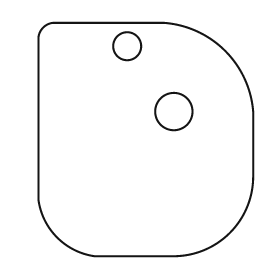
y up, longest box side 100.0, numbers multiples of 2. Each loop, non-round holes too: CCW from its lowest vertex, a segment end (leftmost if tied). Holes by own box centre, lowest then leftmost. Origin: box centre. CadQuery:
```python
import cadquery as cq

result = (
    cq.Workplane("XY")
    .moveTo(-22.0, -50.0)
    .lineTo(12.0, -50.0)
    .threePointArc((36.0, -40.0), (46.0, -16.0))
    .lineTo(46.0, 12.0)
    .threePointArc((34.0, 38.0), (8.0, 50.0))
    .lineTo(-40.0, 50.0)
    .threePointArc((-44.0, 48.0), (-46.0, 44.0))
    .lineTo(-46.0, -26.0)
    .threePointArc((-38.0, -42.0), (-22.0, -50.0))
    .close()
    .moveTo(12.0, 12.0)
    .circle(8.0)
    .moveTo(-8.0, 40.0)
    .circle(6.0)
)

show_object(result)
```